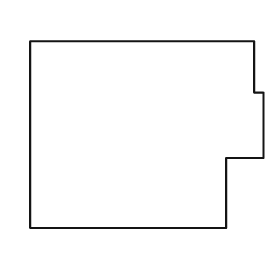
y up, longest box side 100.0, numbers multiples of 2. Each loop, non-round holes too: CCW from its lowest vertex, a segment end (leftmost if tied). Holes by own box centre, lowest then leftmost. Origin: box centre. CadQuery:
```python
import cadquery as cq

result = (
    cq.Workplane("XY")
    .moveTo(-50.0, -40.0)
    .lineTo(34.0, -40.0)
    .lineTo(34.0, -10.0)
    .lineTo(50.0, -10.0)
    .lineTo(50.0, 18.0)
    .lineTo(46.0, 18.0)
    .lineTo(46.0, 40.0)
    .lineTo(-50.0, 40.0)
    .close()
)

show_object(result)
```